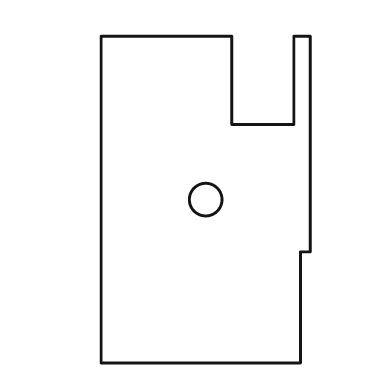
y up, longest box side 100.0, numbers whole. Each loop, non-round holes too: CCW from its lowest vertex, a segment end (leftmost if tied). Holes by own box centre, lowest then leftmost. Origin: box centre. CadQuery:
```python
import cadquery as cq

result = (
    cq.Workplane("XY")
    .moveTo(-32.0, -50.0)
    .lineTo(29.0, -50.0)
    .lineTo(29.0, -16.0)
    .lineTo(32.0, -16.0)
    .lineTo(32.0, 50.0)
    .lineTo(27.0, 50.0)
    .lineTo(27.0, 23.0)
    .lineTo(8.0, 23.0)
    .lineTo(8.0, 50.0)
    .lineTo(-32.0, 50.0)
    .close()
    .moveTo(0.0, 0.0)
    .circle(5.0)
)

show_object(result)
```